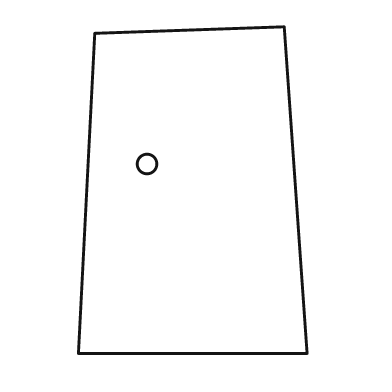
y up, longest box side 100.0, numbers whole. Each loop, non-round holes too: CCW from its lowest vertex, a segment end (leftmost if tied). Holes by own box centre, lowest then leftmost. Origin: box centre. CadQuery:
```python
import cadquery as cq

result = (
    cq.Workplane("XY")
    .moveTo(-35.0, -50.0)
    .lineTo(35.0, -50.0)
    .lineTo(28.0, 50.0)
    .lineTo(-30.0, 48.0)
    .close()
    .moveTo(-14.0, 8.0)
    .circle(3.0)
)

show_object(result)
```